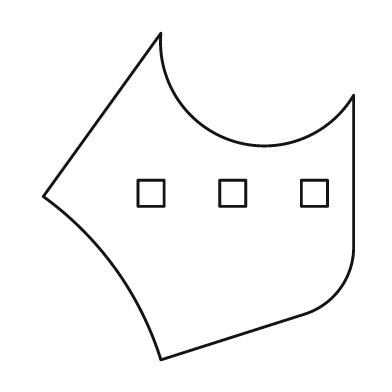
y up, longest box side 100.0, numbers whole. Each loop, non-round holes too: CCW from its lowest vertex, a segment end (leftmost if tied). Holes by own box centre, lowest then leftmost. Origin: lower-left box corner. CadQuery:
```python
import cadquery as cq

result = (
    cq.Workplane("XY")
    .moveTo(36.0, 0.0)
    .lineTo(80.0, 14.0)
    .threePointArc((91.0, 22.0), (95.0, 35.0))
    .lineTo(95.0, 81.0)
    .threePointArc((58.0, 67.0), (36.0, 100.0))
    .lineTo(0.0, 50.0)
    .threePointArc((22.0, 28.0), (36.0, 0.0))
    .close()
    .moveTo(29.0, 47.0)
    .lineTo(37.0, 47.0)
    .lineTo(37.0, 55.0)
    .lineTo(29.0, 55.0)
    .close()
    .moveTo(54.0, 47.0)
    .lineTo(62.0, 47.0)
    .lineTo(62.0, 55.0)
    .lineTo(54.0, 55.0)
    .close()
    .moveTo(79.0, 47.0)
    .lineTo(87.0, 47.0)
    .lineTo(87.0, 55.0)
    .lineTo(79.0, 55.0)
    .close()
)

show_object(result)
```